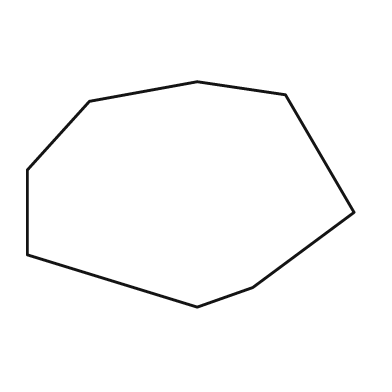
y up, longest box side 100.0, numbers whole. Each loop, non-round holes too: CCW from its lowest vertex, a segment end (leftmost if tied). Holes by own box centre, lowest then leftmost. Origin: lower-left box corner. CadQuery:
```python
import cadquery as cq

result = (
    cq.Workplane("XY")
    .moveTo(52.0, 0.0)
    .lineTo(69.0, 6.0)
    .lineTo(100.0, 29.0)
    .lineTo(79.0, 65.0)
    .lineTo(52.0, 69.0)
    .lineTo(19.0, 63.0)
    .lineTo(0.0, 42.0)
    .lineTo(0.0, 16.0)
    .close()
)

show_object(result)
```